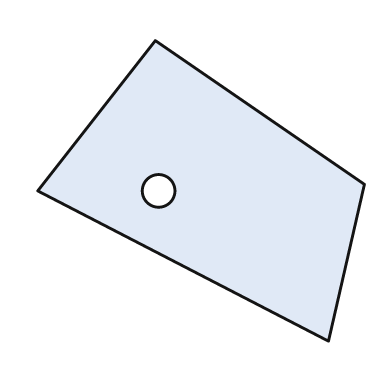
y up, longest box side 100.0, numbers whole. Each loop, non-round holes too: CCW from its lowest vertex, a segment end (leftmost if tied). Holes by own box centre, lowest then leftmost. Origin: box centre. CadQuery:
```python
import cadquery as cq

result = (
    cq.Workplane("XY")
    .moveTo(39.0, -46.0)
    .lineTo(50.0, 2.0)
    .lineTo(-14.0, 46.0)
    .lineTo(-50.0, 0.0)
    .close()
    .moveTo(-13.0, 0.0)
    .circle(5.0)
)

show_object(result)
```